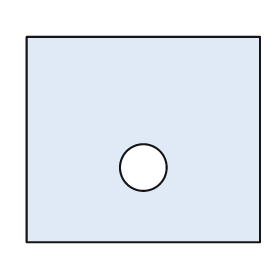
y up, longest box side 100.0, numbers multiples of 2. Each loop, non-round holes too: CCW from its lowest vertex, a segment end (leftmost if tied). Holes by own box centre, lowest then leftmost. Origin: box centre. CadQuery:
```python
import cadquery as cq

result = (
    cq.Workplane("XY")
    .moveTo(-50.0, -44.0)
    .lineTo(50.0, -44.0)
    .lineTo(50.0, 44.0)
    .lineTo(-50.0, 44.0)
    .close()
    .moveTo(0.0, -12.0)
    .circle(10.0)
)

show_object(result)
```